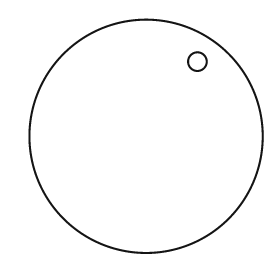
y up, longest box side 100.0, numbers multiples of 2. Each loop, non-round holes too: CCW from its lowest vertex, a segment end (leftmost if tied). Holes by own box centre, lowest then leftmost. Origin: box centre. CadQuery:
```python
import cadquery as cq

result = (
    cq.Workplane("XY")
    .moveTo(0.0, 0.0)
    .circle(50.0)
    .moveTo(22.0, 32.0)
    .circle(4.0)
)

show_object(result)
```